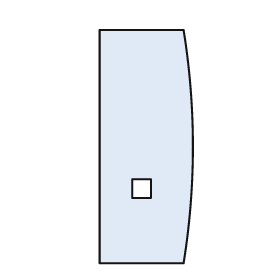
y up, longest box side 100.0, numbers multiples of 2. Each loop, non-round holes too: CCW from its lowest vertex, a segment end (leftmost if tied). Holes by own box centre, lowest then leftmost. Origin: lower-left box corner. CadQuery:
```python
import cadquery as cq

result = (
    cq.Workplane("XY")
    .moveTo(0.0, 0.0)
    .lineTo(36.0, 0.0)
    .threePointArc((40.0, 50.0), (36.0, 100.0))
    .lineTo(0.0, 100.0)
    .close()
    .moveTo(14.0, 28.0)
    .lineTo(22.0, 28.0)
    .lineTo(22.0, 36.0)
    .lineTo(14.0, 36.0)
    .close()
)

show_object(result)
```